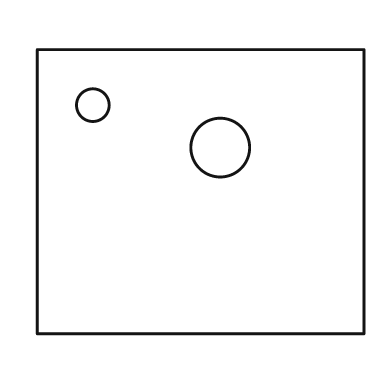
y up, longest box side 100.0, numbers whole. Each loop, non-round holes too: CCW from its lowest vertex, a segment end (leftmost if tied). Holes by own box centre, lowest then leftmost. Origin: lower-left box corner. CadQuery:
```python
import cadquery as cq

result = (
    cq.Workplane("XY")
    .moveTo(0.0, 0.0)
    .lineTo(100.0, 0.0)
    .lineTo(100.0, 87.0)
    .lineTo(0.0, 87.0)
    .close()
    .moveTo(56.0, 57.0)
    .circle(9.0)
    .moveTo(17.0, 70.0)
    .circle(5.0)
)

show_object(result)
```